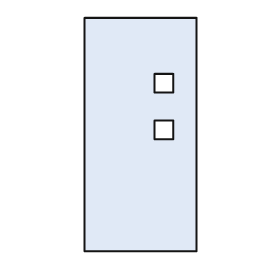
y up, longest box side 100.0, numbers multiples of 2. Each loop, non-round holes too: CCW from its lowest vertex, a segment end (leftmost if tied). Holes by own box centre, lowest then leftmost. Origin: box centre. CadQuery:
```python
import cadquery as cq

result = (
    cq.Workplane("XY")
    .moveTo(-24.0, -50.0)
    .lineTo(24.0, -50.0)
    .lineTo(24.0, 50.0)
    .lineTo(-24.0, 50.0)
    .close()
    .moveTo(6.0, -2.0)
    .lineTo(14.0, -2.0)
    .lineTo(14.0, 6.0)
    .lineTo(6.0, 6.0)
    .close()
    .moveTo(6.0, 18.0)
    .lineTo(14.0, 18.0)
    .lineTo(14.0, 26.0)
    .lineTo(6.0, 26.0)
    .close()
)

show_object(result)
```